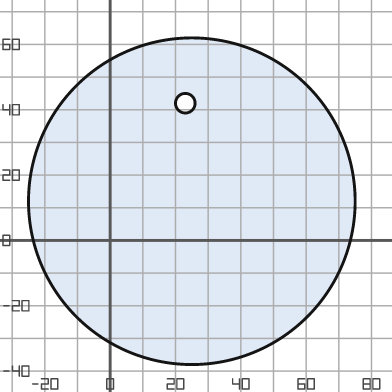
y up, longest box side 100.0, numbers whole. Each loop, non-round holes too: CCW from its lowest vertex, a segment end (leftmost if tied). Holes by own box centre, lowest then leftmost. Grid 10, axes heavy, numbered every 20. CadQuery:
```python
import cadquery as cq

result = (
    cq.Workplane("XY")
    .moveTo(25.0, 12.0)
    .circle(50.0)
    .moveTo(23.0, 42.0)
    .circle(3.0)
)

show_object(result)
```